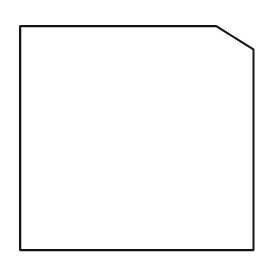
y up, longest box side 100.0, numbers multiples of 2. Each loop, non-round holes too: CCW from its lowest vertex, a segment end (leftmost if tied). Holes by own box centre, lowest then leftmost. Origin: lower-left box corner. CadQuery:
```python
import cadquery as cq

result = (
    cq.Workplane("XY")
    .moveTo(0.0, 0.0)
    .lineTo(100.0, 0.0)
    .lineTo(100.0, 86.0)
    .lineTo(84.0, 96.0)
    .lineTo(0.0, 96.0)
    .close()
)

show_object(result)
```